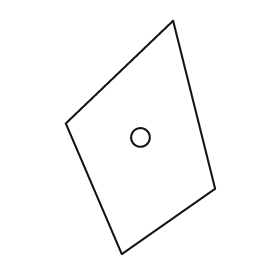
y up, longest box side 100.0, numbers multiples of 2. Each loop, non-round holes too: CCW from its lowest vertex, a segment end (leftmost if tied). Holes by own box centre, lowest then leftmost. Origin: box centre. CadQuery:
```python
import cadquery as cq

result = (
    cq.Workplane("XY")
    .moveTo(-8.0, -50.0)
    .lineTo(32.0, -22.0)
    .lineTo(14.0, 50.0)
    .lineTo(-32.0, 6.0)
    .close()
    .moveTo(0.0, 0.0)
    .circle(4.0)
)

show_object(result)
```